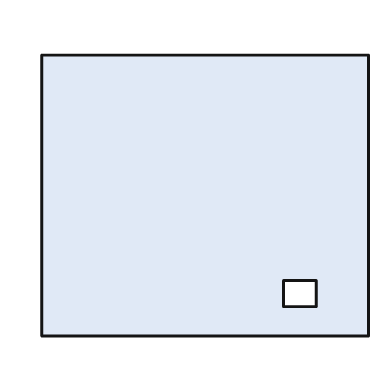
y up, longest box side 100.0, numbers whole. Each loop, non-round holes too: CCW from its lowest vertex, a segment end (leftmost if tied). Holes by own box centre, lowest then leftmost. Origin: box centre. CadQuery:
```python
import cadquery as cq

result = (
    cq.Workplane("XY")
    .moveTo(-50.0, -43.0)
    .lineTo(50.0, -43.0)
    .lineTo(50.0, 43.0)
    .lineTo(-50.0, 43.0)
    .close()
    .moveTo(24.0, -34.0)
    .lineTo(34.0, -34.0)
    .lineTo(34.0, -26.0)
    .lineTo(24.0, -26.0)
    .close()
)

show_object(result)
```